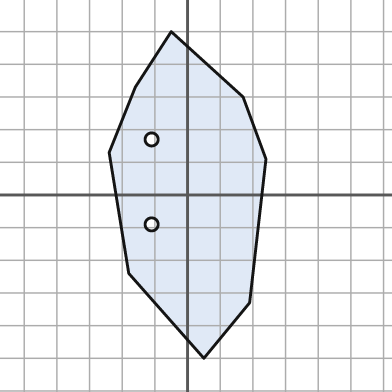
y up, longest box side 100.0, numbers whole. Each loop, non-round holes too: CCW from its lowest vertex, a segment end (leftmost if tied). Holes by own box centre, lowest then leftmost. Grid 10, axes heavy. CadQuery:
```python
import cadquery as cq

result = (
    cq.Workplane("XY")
    .moveTo(5.0, -50.0)
    .lineTo(19.0, -33.0)
    .lineTo(24.0, 11.0)
    .lineTo(17.0, 30.0)
    .lineTo(-5.0, 50.0)
    .lineTo(-16.0, 33.0)
    .lineTo(-24.0, 13.0)
    .lineTo(-18.0, -24.0)
    .close()
    .moveTo(-11.0, -9.0)
    .circle(2.0)
    .moveTo(-11.0, 17.0)
    .circle(2.0)
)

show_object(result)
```